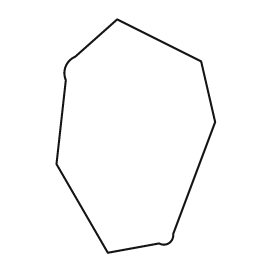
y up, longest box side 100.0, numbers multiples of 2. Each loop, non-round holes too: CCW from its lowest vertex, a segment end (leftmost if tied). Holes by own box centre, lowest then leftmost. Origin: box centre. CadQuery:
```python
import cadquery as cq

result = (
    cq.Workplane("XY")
    .moveTo(-12.0, -50.0)
    .lineTo(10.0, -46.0)
    .threePointArc((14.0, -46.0), (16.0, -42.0))
    .lineTo(34.0, 6.0)
    .lineTo(28.0, 32.0)
    .lineTo(-8.0, 50.0)
    .lineTo(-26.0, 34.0)
    .threePointArc((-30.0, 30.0), (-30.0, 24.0))
    .lineTo(-34.0, -12.0)
    .close()
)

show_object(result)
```